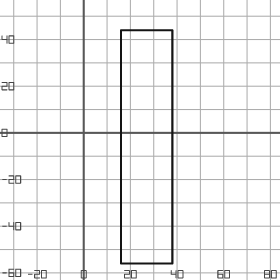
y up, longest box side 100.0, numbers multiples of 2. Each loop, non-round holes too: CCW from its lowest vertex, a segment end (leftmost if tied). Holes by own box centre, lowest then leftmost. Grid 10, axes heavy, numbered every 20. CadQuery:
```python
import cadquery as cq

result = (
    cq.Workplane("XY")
    .moveTo(16.0, -56.0)
    .lineTo(38.0, -56.0)
    .lineTo(38.0, 44.0)
    .lineTo(16.0, 44.0)
    .close()
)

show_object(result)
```